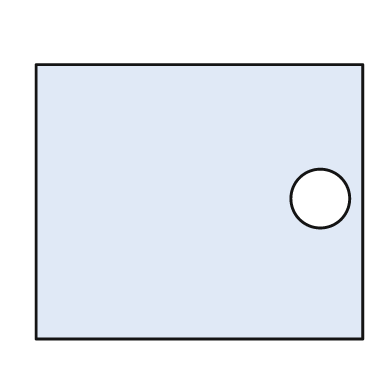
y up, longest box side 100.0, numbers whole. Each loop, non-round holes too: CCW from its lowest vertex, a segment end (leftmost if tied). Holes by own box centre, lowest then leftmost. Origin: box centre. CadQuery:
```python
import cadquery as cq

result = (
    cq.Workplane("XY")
    .moveTo(-50.0, -42.0)
    .lineTo(50.0, -42.0)
    .lineTo(50.0, 42.0)
    .lineTo(-50.0, 42.0)
    .close()
    .moveTo(37.0, 1.0)
    .circle(9.0)
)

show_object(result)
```